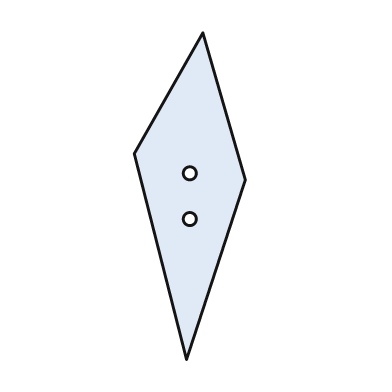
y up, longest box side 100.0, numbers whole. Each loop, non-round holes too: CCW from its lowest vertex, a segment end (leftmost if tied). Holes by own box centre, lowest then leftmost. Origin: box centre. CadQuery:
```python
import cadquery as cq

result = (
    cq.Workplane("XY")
    .moveTo(-1.0, -50.0)
    .lineTo(17.0, 5.0)
    .lineTo(4.0, 50.0)
    .lineTo(-17.0, 13.0)
    .close()
    .moveTo(0.0, -7.0)
    .circle(2.0)
    .moveTo(0.0, 7.0)
    .circle(2.0)
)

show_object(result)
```